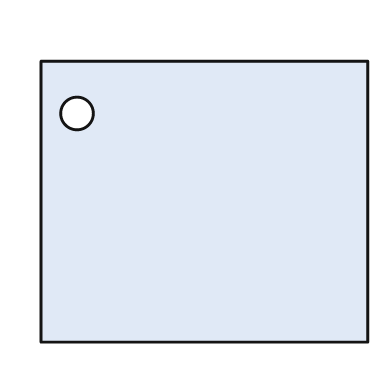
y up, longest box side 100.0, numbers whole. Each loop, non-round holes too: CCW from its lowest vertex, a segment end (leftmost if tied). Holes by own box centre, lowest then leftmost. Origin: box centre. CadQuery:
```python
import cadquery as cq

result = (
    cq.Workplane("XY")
    .moveTo(-50.0, -43.0)
    .lineTo(50.0, -43.0)
    .lineTo(50.0, 43.0)
    .lineTo(-50.0, 43.0)
    .close()
    .moveTo(-39.0, 27.0)
    .circle(5.0)
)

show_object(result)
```